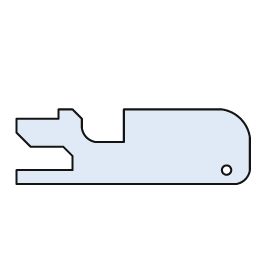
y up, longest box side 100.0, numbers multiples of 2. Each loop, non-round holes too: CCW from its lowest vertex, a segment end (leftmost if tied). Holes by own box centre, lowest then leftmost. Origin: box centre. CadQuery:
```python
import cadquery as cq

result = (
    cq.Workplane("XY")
    .moveTo(-50.0, -16.0)
    .lineTo(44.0, -16.0)
    .threePointArc((48.0, -14.0), (50.0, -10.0))
    .lineTo(50.0, 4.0)
    .threePointArc((46.0, 12.0), (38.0, 16.0))
    .lineTo(-4.0, 16.0)
    .lineTo(-4.0, 2.0)
    .lineTo(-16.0, 2.0)
    .threePointArc((-20.0, 4.0), (-22.0, 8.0))
    .lineTo(-22.0, 12.0)
    .lineTo(-26.0, 16.0)
    .lineTo(-32.0, 16.0)
    .lineTo(-32.0, 12.0)
    .lineTo(-50.0, 12.0)
    .lineTo(-50.0, 6.0)
    .lineTo(-44.0, 0.0)
    .lineTo(-30.0, 0.0)
    .lineTo(-26.0, -4.0)
    .lineTo(-26.0, -10.0)
    .lineTo(-50.0, -10.0)
    .close()
    .moveTo(40.0, -10.0)
    .circle(2.0)
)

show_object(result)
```